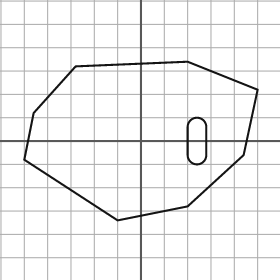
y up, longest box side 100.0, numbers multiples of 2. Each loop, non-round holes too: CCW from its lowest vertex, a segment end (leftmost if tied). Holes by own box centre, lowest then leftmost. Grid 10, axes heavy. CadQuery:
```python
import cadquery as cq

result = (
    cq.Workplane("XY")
    .moveTo(-10.0, -34.0)
    .lineTo(20.0, -28.0)
    .lineTo(44.0, -6.0)
    .lineTo(50.0, 22.0)
    .lineTo(20.0, 34.0)
    .lineTo(-28.0, 32.0)
    .lineTo(-46.0, 12.0)
    .lineTo(-50.0, -8.0)
    .close()
    .moveTo(20.0, -6.0)
    .threePointArc((24.0, -10.0), (28.0, -6.0))
    .lineTo(28.0, 6.0)
    .threePointArc((24.0, 10.0), (20.0, 6.0))
    .close()
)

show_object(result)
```